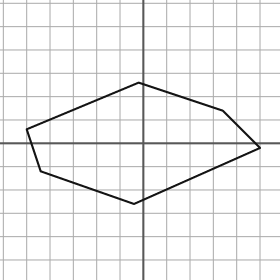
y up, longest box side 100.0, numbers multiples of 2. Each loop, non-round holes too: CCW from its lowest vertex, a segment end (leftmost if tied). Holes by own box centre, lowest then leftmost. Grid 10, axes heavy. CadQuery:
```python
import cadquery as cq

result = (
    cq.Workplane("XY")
    .moveTo(-4.0, -26.0)
    .lineTo(50.0, -2.0)
    .lineTo(34.0, 14.0)
    .lineTo(-2.0, 26.0)
    .lineTo(-50.0, 6.0)
    .lineTo(-44.0, -12.0)
    .close()
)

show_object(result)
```